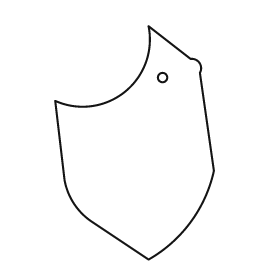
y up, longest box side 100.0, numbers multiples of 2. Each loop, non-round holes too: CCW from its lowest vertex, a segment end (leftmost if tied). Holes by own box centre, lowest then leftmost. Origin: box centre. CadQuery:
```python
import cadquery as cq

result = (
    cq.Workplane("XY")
    .moveTo(6.0, -50.0)
    .threePointArc((24.0, -34.0), (34.0, -12.0))
    .lineTo(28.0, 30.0)
    .threePointArc((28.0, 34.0), (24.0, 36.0))
    .lineTo(6.0, 50.0)
    .threePointArc((-4.0, 22.0), (-34.0, 18.0))
    .lineTo(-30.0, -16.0)
    .threePointArc((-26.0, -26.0), (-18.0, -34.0))
    .close()
    .moveTo(12.0, 28.0)
    .circle(2.0)
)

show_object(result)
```